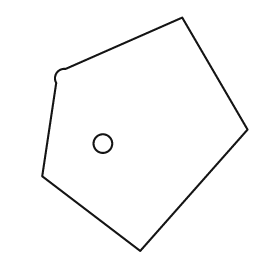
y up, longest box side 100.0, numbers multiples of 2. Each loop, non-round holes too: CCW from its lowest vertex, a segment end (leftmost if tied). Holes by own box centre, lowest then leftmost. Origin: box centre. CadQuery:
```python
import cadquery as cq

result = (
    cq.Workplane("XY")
    .moveTo(-2.0, -50.0)
    .lineTo(44.0, 2.0)
    .lineTo(16.0, 50.0)
    .lineTo(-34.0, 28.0)
    .threePointArc((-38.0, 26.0), (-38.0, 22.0))
    .lineTo(-44.0, -18.0)
    .close()
    .moveTo(-18.0, -4.0)
    .circle(4.0)
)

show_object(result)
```